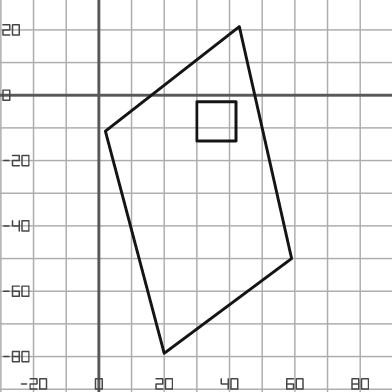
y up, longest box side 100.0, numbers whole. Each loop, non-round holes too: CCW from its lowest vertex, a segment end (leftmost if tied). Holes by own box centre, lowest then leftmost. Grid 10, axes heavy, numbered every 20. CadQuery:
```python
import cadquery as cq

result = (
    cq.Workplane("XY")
    .moveTo(20.0, -79.0)
    .lineTo(59.0, -50.0)
    .lineTo(43.0, 21.0)
    .lineTo(2.0, -11.0)
    .close()
    .moveTo(30.0, -14.0)
    .lineTo(42.0, -14.0)
    .lineTo(42.0, -2.0)
    .lineTo(30.0, -2.0)
    .close()
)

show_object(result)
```